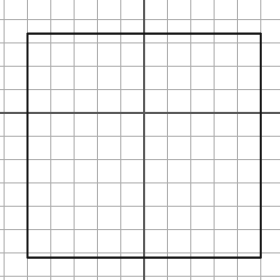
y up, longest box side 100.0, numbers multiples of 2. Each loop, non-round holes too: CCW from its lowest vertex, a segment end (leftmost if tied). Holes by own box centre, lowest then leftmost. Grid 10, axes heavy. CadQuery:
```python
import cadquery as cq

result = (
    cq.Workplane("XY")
    .moveTo(-50.0, -62.0)
    .lineTo(50.0, -62.0)
    .lineTo(50.0, 34.0)
    .lineTo(-50.0, 34.0)
    .close()
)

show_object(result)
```